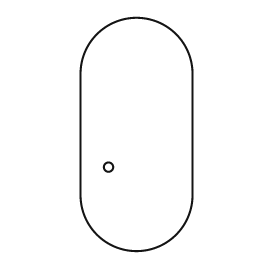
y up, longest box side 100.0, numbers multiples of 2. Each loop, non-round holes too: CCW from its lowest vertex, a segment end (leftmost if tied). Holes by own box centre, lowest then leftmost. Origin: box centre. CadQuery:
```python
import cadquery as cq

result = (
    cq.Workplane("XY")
    .moveTo(-24.0, -26.0)
    .threePointArc((0.0, -50.0), (24.0, -26.0))
    .lineTo(24.0, 26.0)
    .threePointArc((0.0, 50.0), (-24.0, 26.0))
    .close()
    .moveTo(-12.0, -14.0)
    .circle(2.0)
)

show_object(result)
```